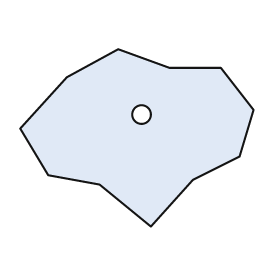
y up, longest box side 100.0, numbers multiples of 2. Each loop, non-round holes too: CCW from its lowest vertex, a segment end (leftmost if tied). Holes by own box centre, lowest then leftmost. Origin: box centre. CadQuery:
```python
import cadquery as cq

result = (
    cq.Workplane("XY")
    .moveTo(6.0, -38.0)
    .lineTo(24.0, -18.0)
    .lineTo(44.0, -8.0)
    .lineTo(50.0, 12.0)
    .lineTo(36.0, 30.0)
    .lineTo(14.0, 30.0)
    .lineTo(-8.0, 38.0)
    .lineTo(-30.0, 26.0)
    .lineTo(-50.0, 4.0)
    .lineTo(-38.0, -16.0)
    .lineTo(-16.0, -20.0)
    .close()
    .moveTo(2.0, 10.0)
    .circle(4.0)
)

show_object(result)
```